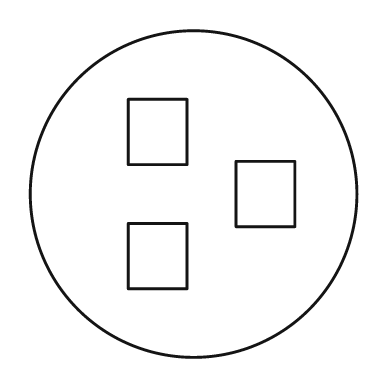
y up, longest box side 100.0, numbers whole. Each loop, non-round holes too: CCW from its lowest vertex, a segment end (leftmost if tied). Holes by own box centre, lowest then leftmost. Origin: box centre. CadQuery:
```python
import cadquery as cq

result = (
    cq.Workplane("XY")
    .moveTo(0.0, 0.0)
    .circle(50.0)
    .moveTo(-20.0, -29.0)
    .lineTo(-2.0, -29.0)
    .lineTo(-2.0, -9.0)
    .lineTo(-20.0, -9.0)
    .close()
    .moveTo(13.0, -10.0)
    .lineTo(31.0, -10.0)
    .lineTo(31.0, 10.0)
    .lineTo(13.0, 10.0)
    .close()
    .moveTo(-20.0, 9.0)
    .lineTo(-2.0, 9.0)
    .lineTo(-2.0, 29.0)
    .lineTo(-20.0, 29.0)
    .close()
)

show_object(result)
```